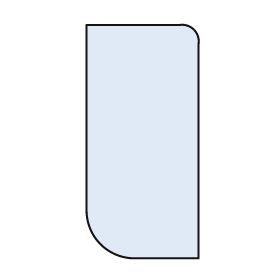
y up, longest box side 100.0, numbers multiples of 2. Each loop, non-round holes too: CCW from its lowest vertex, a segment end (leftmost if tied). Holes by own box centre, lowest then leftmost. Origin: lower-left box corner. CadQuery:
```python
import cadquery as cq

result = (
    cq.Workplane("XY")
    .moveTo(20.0, 0.0)
    .lineTo(48.0, 0.0)
    .lineTo(48.0, 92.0)
    .threePointArc((46.0, 98.0), (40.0, 100.0))
    .lineTo(0.0, 100.0)
    .lineTo(0.0, 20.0)
    .threePointArc((6.0, 6.0), (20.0, 0.0))
    .close()
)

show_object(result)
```